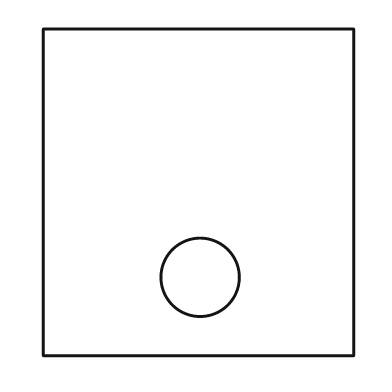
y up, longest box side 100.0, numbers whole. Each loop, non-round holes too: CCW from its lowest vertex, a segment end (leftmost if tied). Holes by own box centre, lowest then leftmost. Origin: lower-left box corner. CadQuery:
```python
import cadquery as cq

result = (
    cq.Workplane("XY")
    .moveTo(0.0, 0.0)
    .lineTo(95.0, 0.0)
    .lineTo(95.0, 100.0)
    .lineTo(0.0, 100.0)
    .close()
    .moveTo(48.0, 24.0)
    .circle(12.0)
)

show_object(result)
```